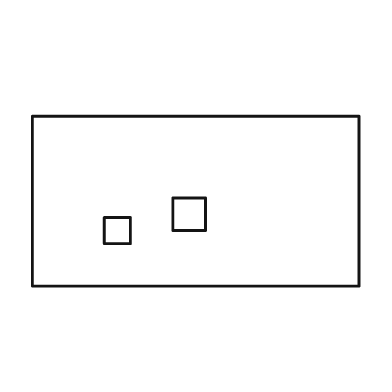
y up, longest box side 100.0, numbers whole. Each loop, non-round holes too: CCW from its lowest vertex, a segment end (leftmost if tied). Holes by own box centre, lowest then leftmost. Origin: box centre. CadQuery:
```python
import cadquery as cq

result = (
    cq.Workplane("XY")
    .moveTo(-50.0, -26.0)
    .lineTo(50.0, -26.0)
    .lineTo(50.0, 26.0)
    .lineTo(-50.0, 26.0)
    .close()
    .moveTo(-28.0, -13.0)
    .lineTo(-20.0, -13.0)
    .lineTo(-20.0, -5.0)
    .lineTo(-28.0, -5.0)
    .close()
    .moveTo(-7.0, -9.0)
    .lineTo(3.0, -9.0)
    .lineTo(3.0, 1.0)
    .lineTo(-7.0, 1.0)
    .close()
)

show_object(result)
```